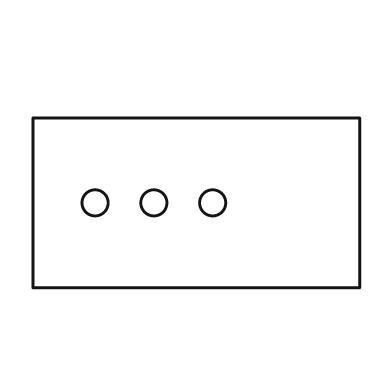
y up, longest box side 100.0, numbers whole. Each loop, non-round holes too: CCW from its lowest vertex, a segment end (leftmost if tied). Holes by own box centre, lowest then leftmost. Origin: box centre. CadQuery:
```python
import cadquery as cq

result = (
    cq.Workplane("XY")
    .moveTo(-50.0, -26.0)
    .lineTo(50.0, -26.0)
    .lineTo(50.0, 26.0)
    .lineTo(-50.0, 26.0)
    .close()
    .moveTo(-31.0, 0.0)
    .circle(4.0)
    .moveTo(-13.0, 0.0)
    .circle(4.0)
    .moveTo(5.0, 0.0)
    .circle(4.0)
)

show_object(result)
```